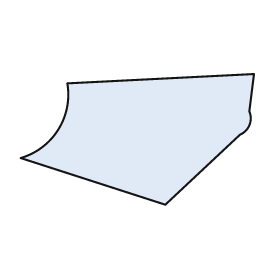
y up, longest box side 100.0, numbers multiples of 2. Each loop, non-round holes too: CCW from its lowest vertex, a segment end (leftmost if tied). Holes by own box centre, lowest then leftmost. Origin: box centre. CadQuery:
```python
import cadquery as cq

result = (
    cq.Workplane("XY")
    .moveTo(12.0, -28.0)
    .lineTo(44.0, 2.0)
    .threePointArc((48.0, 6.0), (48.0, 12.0))
    .lineTo(50.0, 28.0)
    .lineTo(-30.0, 24.0)
    .threePointArc((-34.0, 4.0), (-50.0, -8.0))
    .close()
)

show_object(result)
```